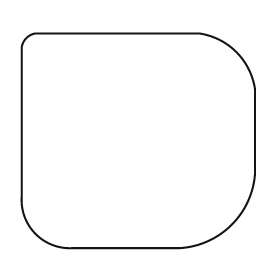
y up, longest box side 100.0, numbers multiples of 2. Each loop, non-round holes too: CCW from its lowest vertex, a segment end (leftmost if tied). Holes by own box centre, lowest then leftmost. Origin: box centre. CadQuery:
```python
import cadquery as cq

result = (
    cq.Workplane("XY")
    .moveTo(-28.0, -46.0)
    .lineTo(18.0, -46.0)
    .threePointArc((40.0, -36.0), (50.0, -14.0))
    .lineTo(50.0, 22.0)
    .threePointArc((42.0, 38.0), (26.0, 46.0))
    .lineTo(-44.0, 46.0)
    .threePointArc((-48.0, 44.0), (-50.0, 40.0))
    .lineTo(-50.0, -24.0)
    .threePointArc((-44.0, -40.0), (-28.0, -46.0))
    .close()
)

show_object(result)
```